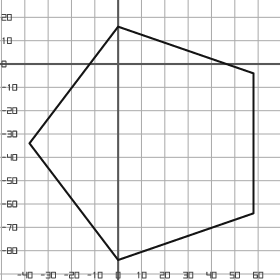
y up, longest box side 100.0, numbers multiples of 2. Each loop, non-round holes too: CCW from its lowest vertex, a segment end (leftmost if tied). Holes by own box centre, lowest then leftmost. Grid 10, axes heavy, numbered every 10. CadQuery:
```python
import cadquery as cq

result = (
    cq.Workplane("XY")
    .moveTo(0.0, -84.0)
    .lineTo(58.0, -64.0)
    .lineTo(58.0, -4.0)
    .lineTo(0.0, 16.0)
    .lineTo(-38.0, -34.0)
    .close()
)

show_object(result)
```